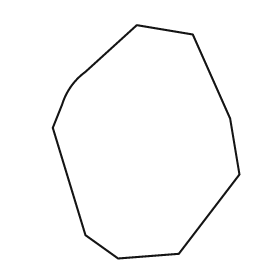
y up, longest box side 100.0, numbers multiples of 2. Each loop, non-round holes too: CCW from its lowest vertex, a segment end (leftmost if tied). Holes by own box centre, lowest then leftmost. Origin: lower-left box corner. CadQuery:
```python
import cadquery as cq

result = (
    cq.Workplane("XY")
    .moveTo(28.0, 0.0)
    .lineTo(54.0, 2.0)
    .lineTo(80.0, 36.0)
    .lineTo(76.0, 60.0)
    .lineTo(60.0, 96.0)
    .lineTo(36.0, 100.0)
    .lineTo(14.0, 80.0)
    .threePointArc((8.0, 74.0), (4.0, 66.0))
    .lineTo(0.0, 56.0)
    .lineTo(14.0, 10.0)
    .close()
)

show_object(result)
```